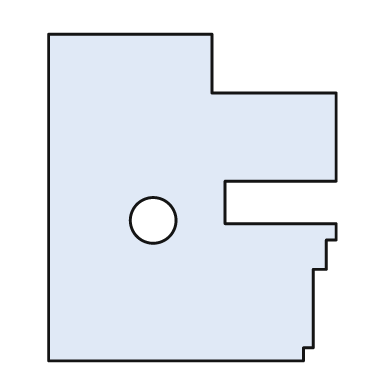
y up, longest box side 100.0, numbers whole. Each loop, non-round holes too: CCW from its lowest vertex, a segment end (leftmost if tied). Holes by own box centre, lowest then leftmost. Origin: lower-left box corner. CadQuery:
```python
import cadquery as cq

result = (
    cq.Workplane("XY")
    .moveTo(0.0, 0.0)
    .lineTo(78.0, 0.0)
    .lineTo(78.0, 4.0)
    .lineTo(81.0, 4.0)
    .lineTo(81.0, 28.0)
    .lineTo(85.0, 28.0)
    .lineTo(85.0, 37.0)
    .lineTo(88.0, 37.0)
    .lineTo(88.0, 42.0)
    .lineTo(54.0, 42.0)
    .lineTo(54.0, 55.0)
    .lineTo(88.0, 55.0)
    .lineTo(88.0, 82.0)
    .lineTo(50.0, 82.0)
    .lineTo(50.0, 100.0)
    .lineTo(0.0, 100.0)
    .close()
    .moveTo(32.0, 43.0)
    .circle(7.0)
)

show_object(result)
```